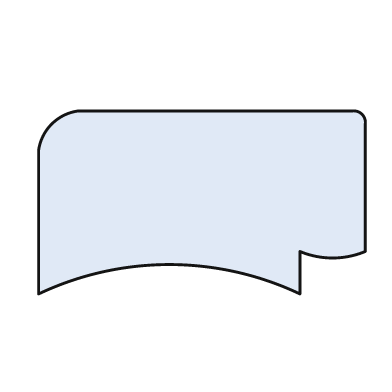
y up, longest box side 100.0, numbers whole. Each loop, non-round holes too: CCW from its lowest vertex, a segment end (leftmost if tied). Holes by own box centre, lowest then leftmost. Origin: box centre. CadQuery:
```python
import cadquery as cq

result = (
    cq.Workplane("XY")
    .moveTo(-50.0, -28.0)
    .threePointArc((-10.0, -19.0), (30.0, -28.0))
    .lineTo(30.0, -15.0)
    .threePointArc((40.0, -17.0), (50.0, -15.0))
    .lineTo(50.0, 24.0)
    .threePointArc((49.0, 27.0), (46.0, 28.0))
    .lineTo(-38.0, 28.0)
    .threePointArc((-46.0, 24.0), (-50.0, 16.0))
    .close()
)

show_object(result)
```